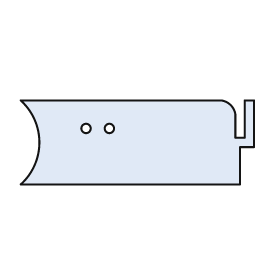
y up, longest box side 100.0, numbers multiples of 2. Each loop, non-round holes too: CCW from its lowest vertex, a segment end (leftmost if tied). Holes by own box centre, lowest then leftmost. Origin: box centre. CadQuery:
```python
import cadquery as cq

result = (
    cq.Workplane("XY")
    .moveTo(-50.0, -18.0)
    .lineTo(44.0, -18.0)
    .lineTo(44.0, -2.0)
    .lineTo(50.0, -2.0)
    .lineTo(50.0, 18.0)
    .lineTo(46.0, 18.0)
    .lineTo(46.0, 2.0)
    .lineTo(42.0, 2.0)
    .lineTo(42.0, 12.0)
    .threePointArc((40.0, 16.0), (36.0, 18.0))
    .lineTo(-50.0, 18.0)
    .threePointArc((-42.0, 0.0), (-50.0, -18.0))
    .close()
    .moveTo(-22.0, 6.0)
    .circle(2.0)
    .moveTo(-12.0, 6.0)
    .circle(2.0)
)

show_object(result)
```